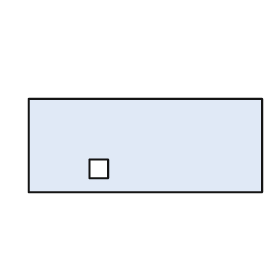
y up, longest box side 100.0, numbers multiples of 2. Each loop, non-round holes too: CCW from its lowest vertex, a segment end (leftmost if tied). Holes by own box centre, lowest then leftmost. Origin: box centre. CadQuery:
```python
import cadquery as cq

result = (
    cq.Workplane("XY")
    .moveTo(-50.0, -20.0)
    .lineTo(50.0, -20.0)
    .lineTo(50.0, 20.0)
    .lineTo(-50.0, 20.0)
    .close()
    .moveTo(-24.0, -14.0)
    .lineTo(-16.0, -14.0)
    .lineTo(-16.0, -6.0)
    .lineTo(-24.0, -6.0)
    .close()
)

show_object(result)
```